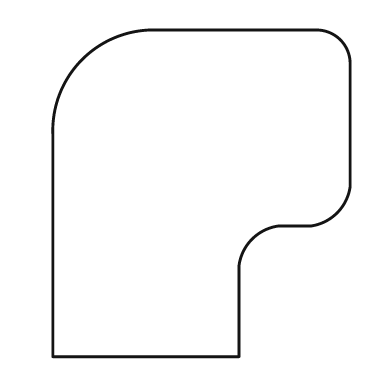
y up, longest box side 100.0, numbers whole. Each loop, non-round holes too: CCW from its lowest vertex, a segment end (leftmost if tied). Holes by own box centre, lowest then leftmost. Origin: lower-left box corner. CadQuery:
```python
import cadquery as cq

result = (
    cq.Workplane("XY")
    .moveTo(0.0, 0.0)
    .lineTo(57.0, 0.0)
    .lineTo(57.0, 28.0)
    .threePointArc((61.0, 36.0), (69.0, 40.0))
    .lineTo(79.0, 40.0)
    .threePointArc((87.0, 44.0), (91.0, 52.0))
    .lineTo(91.0, 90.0)
    .threePointArc((88.0, 97.0), (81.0, 100.0))
    .lineTo(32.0, 100.0)
    .threePointArc((9.0, 91.0), (0.0, 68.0))
    .close()
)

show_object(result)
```